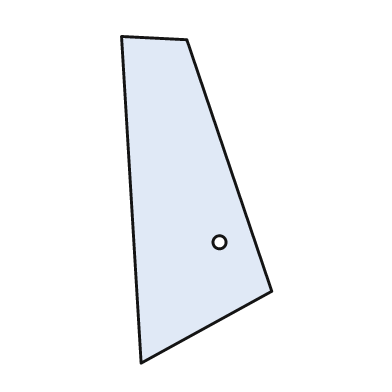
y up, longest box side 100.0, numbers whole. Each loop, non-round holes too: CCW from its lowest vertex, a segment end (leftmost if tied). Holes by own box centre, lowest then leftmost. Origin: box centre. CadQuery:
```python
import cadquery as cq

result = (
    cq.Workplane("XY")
    .moveTo(-17.0, -50.0)
    .lineTo(23.0, -28.0)
    .lineTo(-3.0, 49.0)
    .lineTo(-23.0, 50.0)
    .close()
    .moveTo(7.0, -13.0)
    .circle(2.0)
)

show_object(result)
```